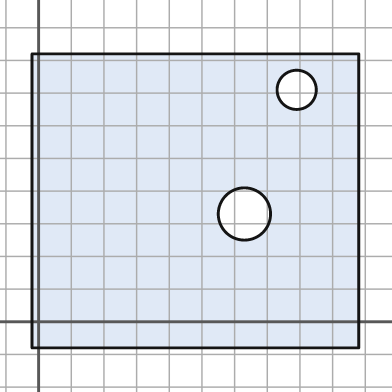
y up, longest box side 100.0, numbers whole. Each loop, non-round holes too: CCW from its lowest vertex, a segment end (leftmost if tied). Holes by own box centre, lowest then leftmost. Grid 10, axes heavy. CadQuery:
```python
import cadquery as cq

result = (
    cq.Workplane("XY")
    .moveTo(-2.0, -8.0)
    .lineTo(98.0, -8.0)
    .lineTo(98.0, 82.0)
    .lineTo(-2.0, 82.0)
    .close()
    .moveTo(63.0, 33.0)
    .circle(8.0)
    .moveTo(79.0, 71.0)
    .circle(6.0)
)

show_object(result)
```